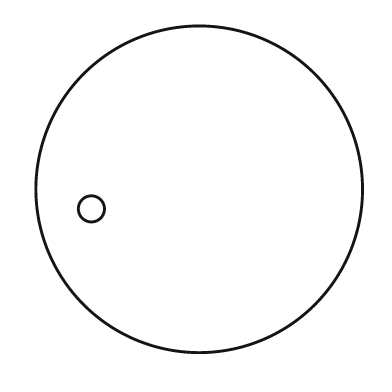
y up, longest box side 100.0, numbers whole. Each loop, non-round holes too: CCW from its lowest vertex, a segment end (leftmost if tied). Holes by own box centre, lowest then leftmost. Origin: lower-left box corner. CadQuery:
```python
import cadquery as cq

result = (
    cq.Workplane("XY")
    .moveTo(50.0, 50.0)
    .circle(50.0)
    .moveTo(17.0, 44.0)
    .circle(4.0)
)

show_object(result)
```